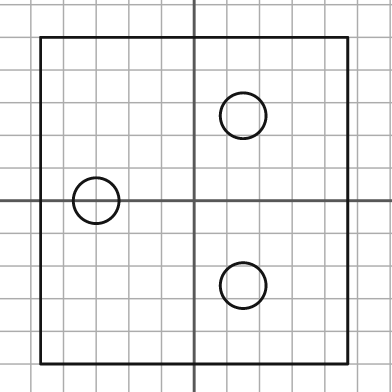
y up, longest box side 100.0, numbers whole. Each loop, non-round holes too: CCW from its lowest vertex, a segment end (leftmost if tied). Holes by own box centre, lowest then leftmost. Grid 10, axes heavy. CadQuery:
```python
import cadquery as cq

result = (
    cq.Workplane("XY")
    .moveTo(-47.0, -50.0)
    .lineTo(47.0, -50.0)
    .lineTo(47.0, 50.0)
    .lineTo(-47.0, 50.0)
    .close()
    .moveTo(15.0, -26.0)
    .circle(7.0)
    .moveTo(-30.0, 0.0)
    .circle(7.0)
    .moveTo(15.0, 26.0)
    .circle(7.0)
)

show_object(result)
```